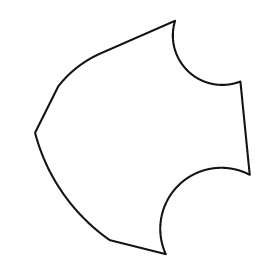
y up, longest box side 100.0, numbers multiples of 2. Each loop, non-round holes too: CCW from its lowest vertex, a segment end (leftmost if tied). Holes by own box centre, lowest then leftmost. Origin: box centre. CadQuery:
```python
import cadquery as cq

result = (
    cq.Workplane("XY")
    .moveTo(10.0, -50.0)
    .threePointArc((16.0, -20.0), (46.0, -16.0))
    .lineTo(42.0, 24.0)
    .threePointArc((20.0, 28.0), (14.0, 50.0))
    .lineTo(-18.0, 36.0)
    .threePointArc((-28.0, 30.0), (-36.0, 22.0))
    .lineTo(-46.0, 2.0)
    .threePointArc((-34.0, -24.0), (-14.0, -44.0))
    .close()
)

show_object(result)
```